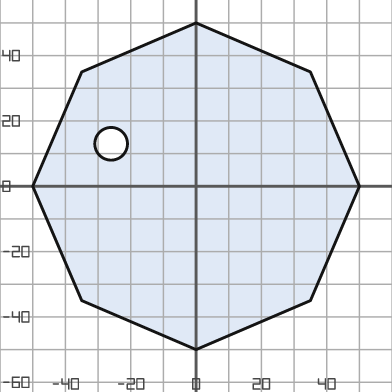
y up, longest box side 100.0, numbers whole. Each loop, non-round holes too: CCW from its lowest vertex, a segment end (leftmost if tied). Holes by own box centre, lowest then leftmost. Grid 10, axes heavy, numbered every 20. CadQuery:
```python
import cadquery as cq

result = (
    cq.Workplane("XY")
    .moveTo(0.0, -50.0)
    .lineTo(35.0, -35.0)
    .lineTo(50.0, 0.0)
    .lineTo(35.0, 35.0)
    .lineTo(0.0, 50.0)
    .lineTo(-35.0, 35.0)
    .lineTo(-50.0, 0.0)
    .lineTo(-35.0, -35.0)
    .close()
    .moveTo(-26.0, 13.0)
    .circle(5.0)
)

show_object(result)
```